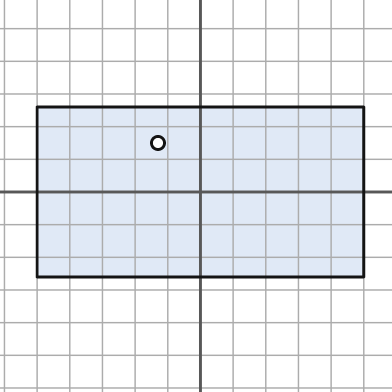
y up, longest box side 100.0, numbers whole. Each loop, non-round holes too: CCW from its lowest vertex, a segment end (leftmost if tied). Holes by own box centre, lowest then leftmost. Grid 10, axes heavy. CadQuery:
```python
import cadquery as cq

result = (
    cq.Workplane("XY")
    .moveTo(-50.0, -26.0)
    .lineTo(50.0, -26.0)
    .lineTo(50.0, 26.0)
    .lineTo(-50.0, 26.0)
    .close()
    .moveTo(-13.0, 15.0)
    .circle(2.0)
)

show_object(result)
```